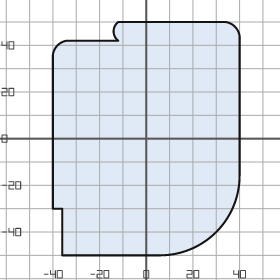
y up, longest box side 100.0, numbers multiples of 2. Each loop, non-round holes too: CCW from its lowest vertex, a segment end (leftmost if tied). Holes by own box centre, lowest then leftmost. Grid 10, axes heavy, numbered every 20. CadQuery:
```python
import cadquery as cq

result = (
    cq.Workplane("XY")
    .moveTo(-36.0, -50.0)
    .lineTo(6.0, -50.0)
    .threePointArc((30.0, -40.0), (40.0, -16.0))
    .lineTo(40.0, 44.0)
    .threePointArc((38.0, 48.0), (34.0, 50.0))
    .lineTo(-12.0, 50.0)
    .threePointArc((-14.0, 46.0), (-12.0, 42.0))
    .lineTo(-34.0, 42.0)
    .threePointArc((-38.0, 40.0), (-40.0, 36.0))
    .lineTo(-40.0, -30.0)
    .lineTo(-36.0, -30.0)
    .close()
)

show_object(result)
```